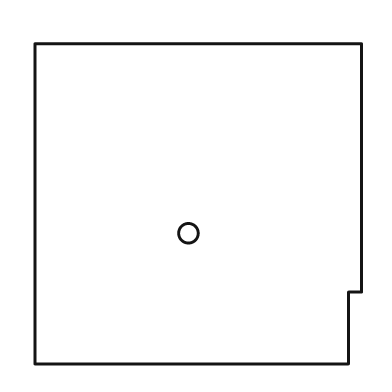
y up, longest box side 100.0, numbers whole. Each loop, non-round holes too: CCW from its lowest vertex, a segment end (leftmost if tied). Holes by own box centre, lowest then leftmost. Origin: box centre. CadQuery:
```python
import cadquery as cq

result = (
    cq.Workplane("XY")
    .moveTo(-50.0, -49.0)
    .lineTo(46.0, -49.0)
    .lineTo(46.0, -27.0)
    .lineTo(50.0, -27.0)
    .lineTo(50.0, 49.0)
    .lineTo(-50.0, 49.0)
    .close()
    .moveTo(-3.0, -9.0)
    .circle(3.0)
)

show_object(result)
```